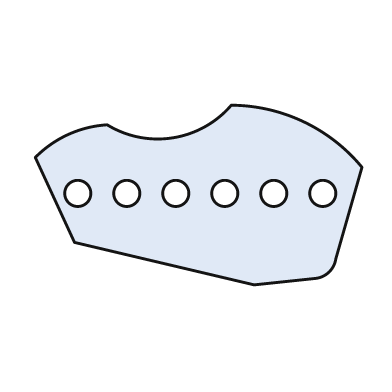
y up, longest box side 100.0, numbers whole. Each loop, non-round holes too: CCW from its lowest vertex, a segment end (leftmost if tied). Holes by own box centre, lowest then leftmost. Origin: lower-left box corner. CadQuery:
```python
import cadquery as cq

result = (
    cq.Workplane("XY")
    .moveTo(67.0, 0.0)
    .lineTo(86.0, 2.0)
    .threePointArc((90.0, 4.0), (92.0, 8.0))
    .lineTo(100.0, 36.0)
    .threePointArc((82.0, 50.0), (60.0, 55.0))
    .threePointArc((42.0, 45.0), (22.0, 49.0))
    .threePointArc((10.0, 46.0), (0.0, 39.0))
    .lineTo(12.0, 13.0)
    .close()
    .moveTo(13.0, 28.0)
    .circle(4.0)
    .moveTo(28.0, 28.0)
    .circle(4.0)
    .moveTo(43.0, 28.0)
    .circle(4.0)
    .moveTo(58.0, 28.0)
    .circle(4.0)
    .moveTo(73.0, 28.0)
    .circle(4.0)
    .moveTo(88.0, 28.0)
    .circle(4.0)
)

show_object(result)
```